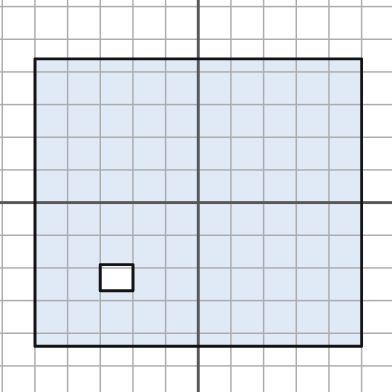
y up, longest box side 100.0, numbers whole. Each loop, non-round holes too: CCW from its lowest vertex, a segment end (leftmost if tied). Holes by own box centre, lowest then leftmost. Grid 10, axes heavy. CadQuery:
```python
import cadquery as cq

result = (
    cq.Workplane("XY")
    .moveTo(-50.0, -44.0)
    .lineTo(50.0, -44.0)
    .lineTo(50.0, 44.0)
    .lineTo(-50.0, 44.0)
    .close()
    .moveTo(-30.0, -27.0)
    .lineTo(-20.0, -27.0)
    .lineTo(-20.0, -19.0)
    .lineTo(-30.0, -19.0)
    .close()
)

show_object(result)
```